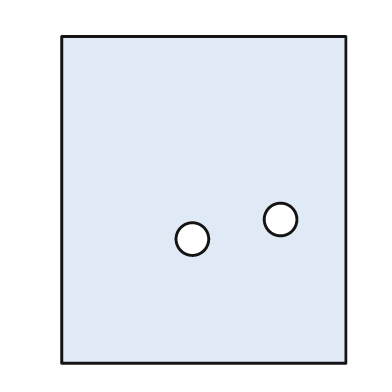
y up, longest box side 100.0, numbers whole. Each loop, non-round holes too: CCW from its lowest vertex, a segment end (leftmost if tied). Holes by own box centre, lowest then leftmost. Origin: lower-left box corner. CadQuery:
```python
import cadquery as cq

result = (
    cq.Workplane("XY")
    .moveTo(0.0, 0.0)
    .lineTo(87.0, 0.0)
    .lineTo(87.0, 100.0)
    .lineTo(0.0, 100.0)
    .close()
    .moveTo(40.0, 38.0)
    .circle(5.0)
    .moveTo(67.0, 44.0)
    .circle(5.0)
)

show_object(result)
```